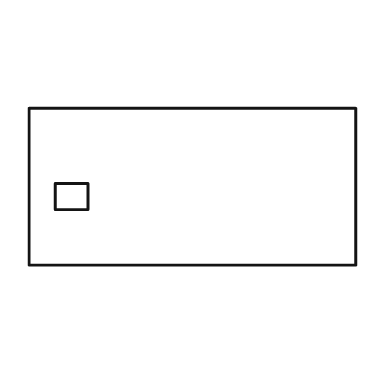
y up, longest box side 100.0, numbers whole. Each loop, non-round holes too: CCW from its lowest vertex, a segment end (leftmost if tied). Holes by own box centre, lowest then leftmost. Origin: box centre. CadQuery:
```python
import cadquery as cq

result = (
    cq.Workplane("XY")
    .moveTo(-50.0, -24.0)
    .lineTo(50.0, -24.0)
    .lineTo(50.0, 24.0)
    .lineTo(-50.0, 24.0)
    .close()
    .moveTo(-42.0, -7.0)
    .lineTo(-32.0, -7.0)
    .lineTo(-32.0, 1.0)
    .lineTo(-42.0, 1.0)
    .close()
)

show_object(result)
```